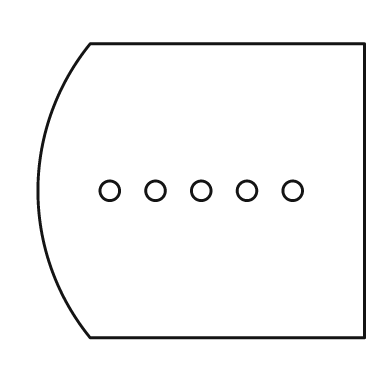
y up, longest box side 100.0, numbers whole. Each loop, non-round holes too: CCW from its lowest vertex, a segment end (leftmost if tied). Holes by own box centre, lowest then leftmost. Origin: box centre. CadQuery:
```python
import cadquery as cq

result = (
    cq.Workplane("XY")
    .moveTo(-34.0, -45.0)
    .lineTo(50.0, -45.0)
    .lineTo(50.0, 45.0)
    .lineTo(-34.0, 45.0)
    .threePointArc((-50.0, 0.0), (-34.0, -45.0))
    .close()
    .moveTo(-28.0, 0.0)
    .circle(3.0)
    .moveTo(-14.0, 0.0)
    .circle(3.0)
    .moveTo(0.0, 0.0)
    .circle(3.0)
    .moveTo(14.0, 0.0)
    .circle(3.0)
    .moveTo(28.0, 0.0)
    .circle(3.0)
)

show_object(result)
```